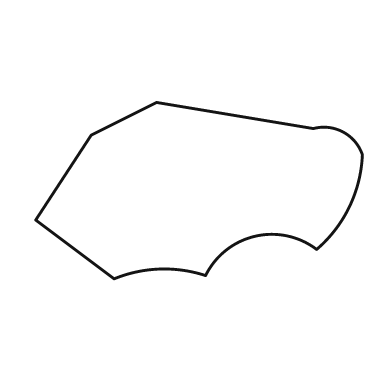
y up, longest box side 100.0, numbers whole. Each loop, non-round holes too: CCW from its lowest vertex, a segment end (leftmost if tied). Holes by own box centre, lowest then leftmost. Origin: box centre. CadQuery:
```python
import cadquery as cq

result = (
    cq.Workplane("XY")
    .moveTo(-26.0, -27.0)
    .threePointArc((-12.0, -24.0), (2.0, -26.0))
    .threePointArc((17.0, -14.0), (36.0, -18.0))
    .threePointArc((46.0, -5.0), (50.0, 11.0))
    .threePointArc((44.0, 18.0), (35.0, 19.0))
    .lineTo(-13.0, 27.0)
    .lineTo(-33.0, 17.0)
    .lineTo(-50.0, -9.0)
    .close()
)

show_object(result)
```